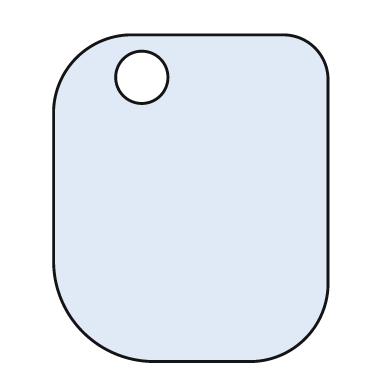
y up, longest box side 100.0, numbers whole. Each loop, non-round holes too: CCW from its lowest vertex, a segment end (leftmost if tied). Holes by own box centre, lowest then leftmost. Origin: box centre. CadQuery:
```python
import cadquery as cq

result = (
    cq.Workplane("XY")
    .moveTo(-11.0, -50.0)
    .lineTo(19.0, -50.0)
    .threePointArc((35.0, -43.0), (42.0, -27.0))
    .lineTo(42.0, 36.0)
    .threePointArc((38.0, 46.0), (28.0, 50.0))
    .lineTo(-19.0, 50.0)
    .threePointArc((-35.0, 43.0), (-42.0, 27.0))
    .lineTo(-42.0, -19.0)
    .threePointArc((-33.0, -41.0), (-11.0, -50.0))
    .close()
    .moveTo(-15.0, 37.0)
    .circle(8.0)
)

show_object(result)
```